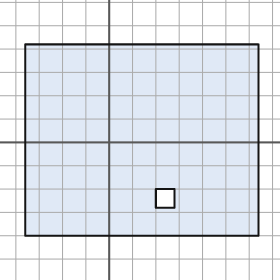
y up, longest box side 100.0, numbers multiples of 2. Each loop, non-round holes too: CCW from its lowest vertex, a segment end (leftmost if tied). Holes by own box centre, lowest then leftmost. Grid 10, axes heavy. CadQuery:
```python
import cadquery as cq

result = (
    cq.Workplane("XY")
    .moveTo(-36.0, -40.0)
    .lineTo(64.0, -40.0)
    .lineTo(64.0, 42.0)
    .lineTo(-36.0, 42.0)
    .close()
    .moveTo(20.0, -28.0)
    .lineTo(28.0, -28.0)
    .lineTo(28.0, -20.0)
    .lineTo(20.0, -20.0)
    .close()
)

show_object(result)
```